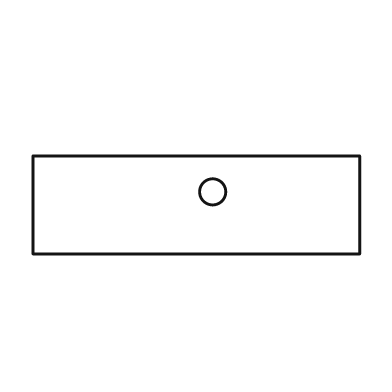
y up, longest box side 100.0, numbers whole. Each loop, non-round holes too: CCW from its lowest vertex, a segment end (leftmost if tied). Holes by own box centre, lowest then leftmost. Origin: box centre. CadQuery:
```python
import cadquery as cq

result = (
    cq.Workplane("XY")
    .moveTo(-50.0, -15.0)
    .lineTo(50.0, -15.0)
    .lineTo(50.0, 15.0)
    .lineTo(-50.0, 15.0)
    .close()
    .moveTo(5.0, 4.0)
    .circle(4.0)
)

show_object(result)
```